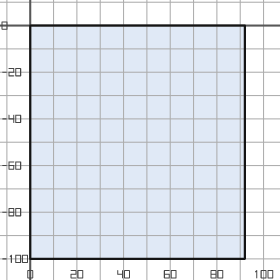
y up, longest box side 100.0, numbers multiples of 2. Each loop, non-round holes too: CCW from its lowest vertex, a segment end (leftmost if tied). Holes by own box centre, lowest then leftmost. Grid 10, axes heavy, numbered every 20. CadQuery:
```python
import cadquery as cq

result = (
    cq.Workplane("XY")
    .moveTo(0.0, -100.0)
    .lineTo(92.0, -100.0)
    .lineTo(92.0, 0.0)
    .lineTo(0.0, 0.0)
    .close()
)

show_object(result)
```